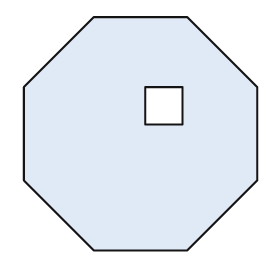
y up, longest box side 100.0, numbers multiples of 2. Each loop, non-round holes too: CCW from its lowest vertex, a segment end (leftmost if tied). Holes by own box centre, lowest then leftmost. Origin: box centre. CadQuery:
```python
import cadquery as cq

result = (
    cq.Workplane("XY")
    .moveTo(-20.0, -50.0)
    .lineTo(20.0, -50.0)
    .lineTo(50.0, -20.0)
    .lineTo(50.0, 20.0)
    .lineTo(20.0, 50.0)
    .lineTo(-20.0, 50.0)
    .lineTo(-50.0, 20.0)
    .lineTo(-50.0, -20.0)
    .close()
    .moveTo(2.0, 4.0)
    .lineTo(18.0, 4.0)
    .lineTo(18.0, 20.0)
    .lineTo(2.0, 20.0)
    .close()
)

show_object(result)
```